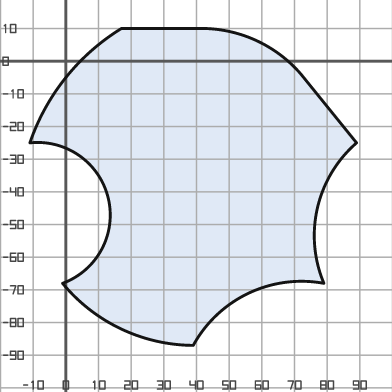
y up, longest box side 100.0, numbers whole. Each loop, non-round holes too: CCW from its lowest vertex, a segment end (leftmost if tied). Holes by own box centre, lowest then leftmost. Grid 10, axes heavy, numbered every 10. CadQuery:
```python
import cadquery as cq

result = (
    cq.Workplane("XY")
    .moveTo(39.0, -87.0)
    .threePointArc((56.0, -71.0), (79.0, -68.0))
    .threePointArc((77.0, -45.0), (89.0, -25.0))
    .lineTo(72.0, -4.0)
    .threePointArc((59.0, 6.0), (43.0, 10.0))
    .lineTo(17.0, 10.0)
    .threePointArc((0.0, -5.0), (-11.0, -25.0))
    .threePointArc((13.0, -42.0), (-1.0, -68.0))
    .threePointArc((17.0, -82.0), (39.0, -87.0))
    .close()
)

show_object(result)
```